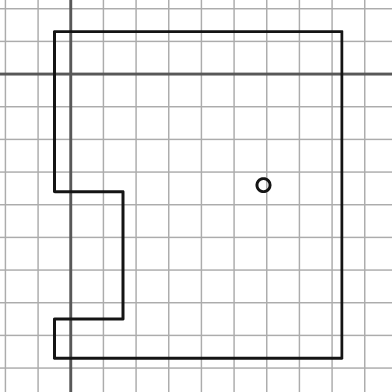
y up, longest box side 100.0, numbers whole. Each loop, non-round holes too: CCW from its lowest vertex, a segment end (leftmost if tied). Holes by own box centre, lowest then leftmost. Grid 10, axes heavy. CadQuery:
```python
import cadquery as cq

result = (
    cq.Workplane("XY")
    .moveTo(-5.0, -87.0)
    .lineTo(83.0, -87.0)
    .lineTo(83.0, 13.0)
    .lineTo(-5.0, 13.0)
    .lineTo(-5.0, -36.0)
    .lineTo(16.0, -36.0)
    .lineTo(16.0, -75.0)
    .lineTo(-5.0, -75.0)
    .close()
    .moveTo(59.0, -34.0)
    .circle(2.0)
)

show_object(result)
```